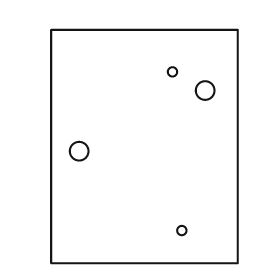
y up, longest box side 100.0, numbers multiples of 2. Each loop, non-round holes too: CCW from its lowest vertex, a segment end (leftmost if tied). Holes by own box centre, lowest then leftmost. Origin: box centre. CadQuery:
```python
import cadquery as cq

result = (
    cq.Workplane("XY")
    .moveTo(-40.0, -50.0)
    .lineTo(40.0, -50.0)
    .lineTo(40.0, 50.0)
    .lineTo(-40.0, 50.0)
    .close()
    .moveTo(16.0, -36.0)
    .circle(2.0)
    .moveTo(-28.0, -2.0)
    .circle(4.0)
    .moveTo(26.0, 24.0)
    .circle(4.0)
    .moveTo(12.0, 32.0)
    .circle(2.0)
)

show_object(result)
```